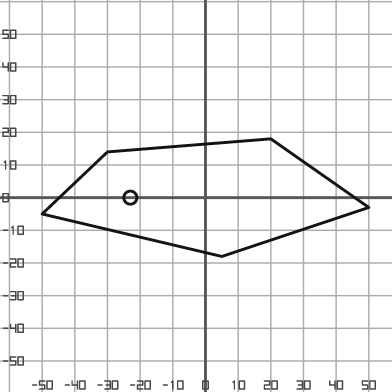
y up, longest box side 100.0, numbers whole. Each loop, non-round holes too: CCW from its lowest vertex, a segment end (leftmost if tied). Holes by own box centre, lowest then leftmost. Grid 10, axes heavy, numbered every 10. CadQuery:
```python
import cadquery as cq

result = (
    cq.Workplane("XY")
    .moveTo(5.0, -18.0)
    .lineTo(50.0, -3.0)
    .lineTo(20.0, 18.0)
    .lineTo(-30.0, 14.0)
    .lineTo(-50.0, -5.0)
    .close()
    .moveTo(-23.0, 0.0)
    .circle(2.0)
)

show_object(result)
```